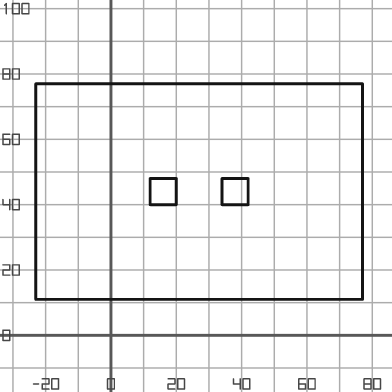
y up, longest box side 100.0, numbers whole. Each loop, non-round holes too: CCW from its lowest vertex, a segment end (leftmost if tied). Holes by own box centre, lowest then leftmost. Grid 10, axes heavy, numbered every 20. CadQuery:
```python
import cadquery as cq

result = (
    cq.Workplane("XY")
    .moveTo(-23.0, 11.0)
    .lineTo(77.0, 11.0)
    .lineTo(77.0, 77.0)
    .lineTo(-23.0, 77.0)
    .close()
    .moveTo(12.0, 40.0)
    .lineTo(20.0, 40.0)
    .lineTo(20.0, 48.0)
    .lineTo(12.0, 48.0)
    .close()
    .moveTo(34.0, 40.0)
    .lineTo(42.0, 40.0)
    .lineTo(42.0, 48.0)
    .lineTo(34.0, 48.0)
    .close()
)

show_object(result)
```